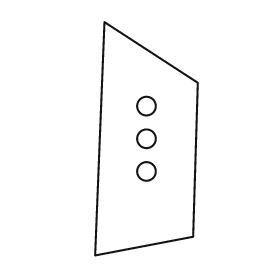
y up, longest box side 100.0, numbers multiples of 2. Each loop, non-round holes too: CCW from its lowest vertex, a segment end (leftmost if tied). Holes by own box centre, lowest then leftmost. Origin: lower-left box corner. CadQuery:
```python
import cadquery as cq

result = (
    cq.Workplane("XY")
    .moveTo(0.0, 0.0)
    .lineTo(42.0, 8.0)
    .lineTo(44.0, 74.0)
    .lineTo(4.0, 100.0)
    .close()
    .moveTo(22.0, 36.0)
    .circle(4.0)
    .moveTo(22.0, 50.0)
    .circle(4.0)
    .moveTo(22.0, 64.0)
    .circle(4.0)
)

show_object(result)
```